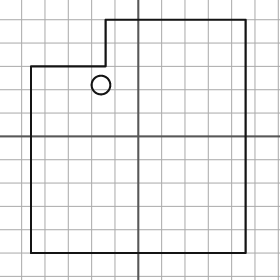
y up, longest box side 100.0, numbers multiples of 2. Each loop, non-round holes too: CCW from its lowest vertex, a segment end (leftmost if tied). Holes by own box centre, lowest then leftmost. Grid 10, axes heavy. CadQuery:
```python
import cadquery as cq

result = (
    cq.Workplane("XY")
    .moveTo(-46.0, -50.0)
    .lineTo(46.0, -50.0)
    .lineTo(46.0, 50.0)
    .lineTo(-14.0, 50.0)
    .lineTo(-14.0, 30.0)
    .lineTo(-46.0, 30.0)
    .close()
    .moveTo(-16.0, 22.0)
    .circle(4.0)
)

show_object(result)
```